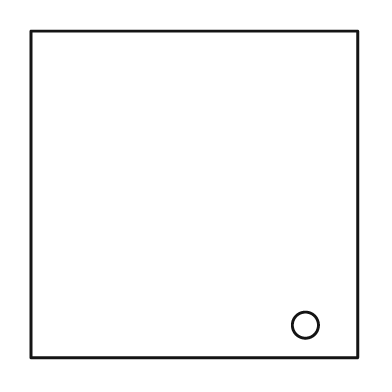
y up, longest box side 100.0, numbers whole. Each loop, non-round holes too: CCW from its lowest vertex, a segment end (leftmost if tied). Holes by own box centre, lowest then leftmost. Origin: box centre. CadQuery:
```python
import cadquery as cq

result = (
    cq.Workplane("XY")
    .moveTo(-50.0, -50.0)
    .lineTo(50.0, -50.0)
    .lineTo(50.0, 50.0)
    .lineTo(-50.0, 50.0)
    .close()
    .moveTo(34.0, -40.0)
    .circle(4.0)
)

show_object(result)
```